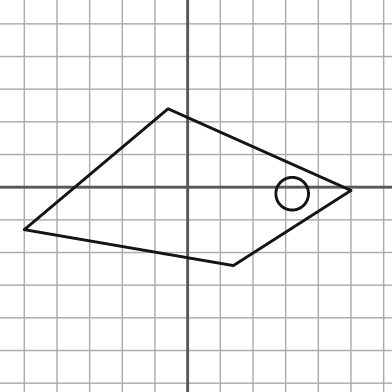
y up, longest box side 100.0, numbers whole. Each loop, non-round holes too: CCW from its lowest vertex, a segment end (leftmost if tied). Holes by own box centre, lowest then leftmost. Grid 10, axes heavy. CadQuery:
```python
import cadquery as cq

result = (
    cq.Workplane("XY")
    .moveTo(14.0, -24.0)
    .lineTo(50.0, -1.0)
    .lineTo(-6.0, 24.0)
    .lineTo(-50.0, -13.0)
    .close()
    .moveTo(32.0, -2.0)
    .circle(5.0)
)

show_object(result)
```